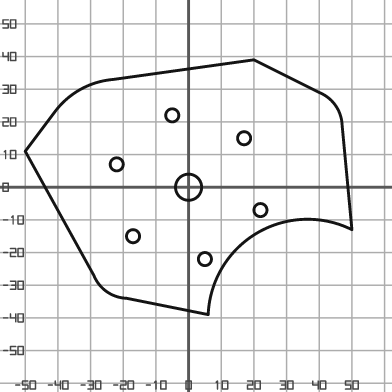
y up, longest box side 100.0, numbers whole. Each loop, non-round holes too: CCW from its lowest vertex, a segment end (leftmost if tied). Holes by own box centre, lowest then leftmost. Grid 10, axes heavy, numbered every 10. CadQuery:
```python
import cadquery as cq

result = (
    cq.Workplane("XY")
    .moveTo(6.0, -39.0)
    .threePointArc((21.0, -14.0), (50.0, -13.0))
    .lineTo(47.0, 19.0)
    .threePointArc((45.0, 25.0), (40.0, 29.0))
    .lineTo(20.0, 39.0)
    .lineTo(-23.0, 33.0)
    .threePointArc((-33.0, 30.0), (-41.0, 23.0))
    .lineTo(-50.0, 11.0)
    .lineTo(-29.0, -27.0)
    .threePointArc((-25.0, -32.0), (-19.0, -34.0))
    .close()
    .moveTo(5.0, -22.0)
    .circle(2.0)
    .moveTo(-17.0, -15.0)
    .circle(2.0)
    .moveTo(22.0, -7.0)
    .circle(2.0)
    .moveTo(0.0, 0.0)
    .circle(4.0)
    .moveTo(-22.0, 7.0)
    .circle(2.0)
    .moveTo(17.0, 15.0)
    .circle(2.0)
    .moveTo(-5.0, 22.0)
    .circle(2.0)
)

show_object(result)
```